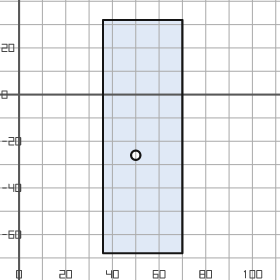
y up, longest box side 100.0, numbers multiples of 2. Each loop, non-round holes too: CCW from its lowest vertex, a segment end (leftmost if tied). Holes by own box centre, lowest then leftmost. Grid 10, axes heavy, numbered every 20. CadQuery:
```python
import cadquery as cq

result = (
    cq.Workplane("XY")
    .moveTo(36.0, -68.0)
    .lineTo(70.0, -68.0)
    .lineTo(70.0, 32.0)
    .lineTo(36.0, 32.0)
    .close()
    .moveTo(50.0, -26.0)
    .circle(2.0)
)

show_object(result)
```